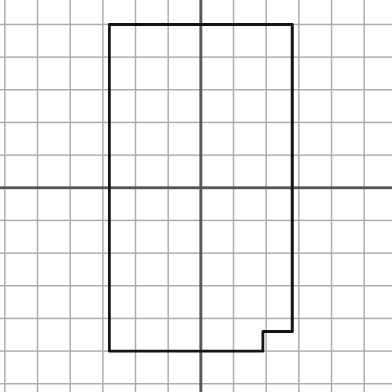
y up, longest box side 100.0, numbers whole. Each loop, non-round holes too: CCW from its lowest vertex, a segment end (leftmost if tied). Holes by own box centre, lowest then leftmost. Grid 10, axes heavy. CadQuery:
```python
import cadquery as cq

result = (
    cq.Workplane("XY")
    .moveTo(-28.0, -50.0)
    .lineTo(19.0, -50.0)
    .lineTo(19.0, -44.0)
    .lineTo(28.0, -44.0)
    .lineTo(28.0, 50.0)
    .lineTo(-28.0, 50.0)
    .close()
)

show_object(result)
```